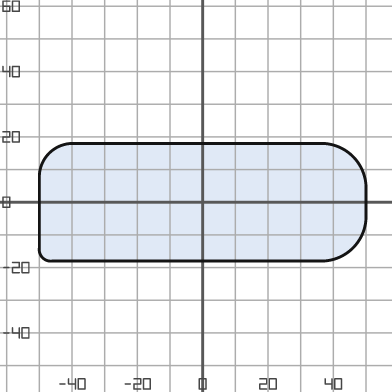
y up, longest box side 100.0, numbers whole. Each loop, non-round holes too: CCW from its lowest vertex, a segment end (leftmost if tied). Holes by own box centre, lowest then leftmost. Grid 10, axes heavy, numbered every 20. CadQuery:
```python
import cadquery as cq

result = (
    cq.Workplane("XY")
    .moveTo(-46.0, -18.0)
    .lineTo(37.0, -18.0)
    .threePointArc((46.0, -14.0), (50.0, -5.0))
    .lineTo(50.0, 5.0)
    .threePointArc((46.0, 14.0), (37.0, 18.0))
    .lineTo(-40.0, 18.0)
    .threePointArc((-47.0, 15.0), (-50.0, 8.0))
    .lineTo(-50.0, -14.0)
    .threePointArc((-49.0, -17.0), (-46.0, -18.0))
    .close()
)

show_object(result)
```